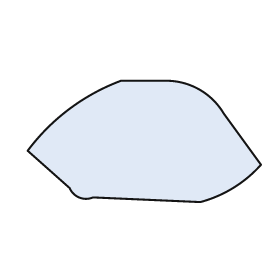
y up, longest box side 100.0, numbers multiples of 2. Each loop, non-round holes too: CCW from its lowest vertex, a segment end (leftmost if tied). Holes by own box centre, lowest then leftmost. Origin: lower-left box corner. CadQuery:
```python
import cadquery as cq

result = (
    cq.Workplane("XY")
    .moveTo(74.0, 0.0)
    .threePointArc((88.0, 6.0), (100.0, 16.0))
    .lineTo(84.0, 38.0)
    .threePointArc((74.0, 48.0), (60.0, 52.0))
    .lineTo(40.0, 52.0)
    .threePointArc((18.0, 40.0), (0.0, 22.0))
    .lineTo(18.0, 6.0)
    .threePointArc((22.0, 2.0), (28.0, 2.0))
    .close()
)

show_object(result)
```